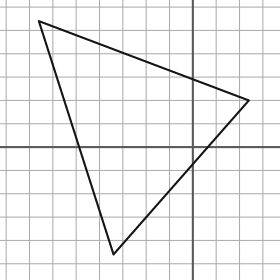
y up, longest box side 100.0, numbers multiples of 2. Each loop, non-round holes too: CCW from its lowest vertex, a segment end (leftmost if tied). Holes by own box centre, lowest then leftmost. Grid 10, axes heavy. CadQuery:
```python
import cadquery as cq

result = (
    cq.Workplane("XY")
    .moveTo(-34.0, -46.0)
    .lineTo(24.0, 20.0)
    .lineTo(-66.0, 54.0)
    .close()
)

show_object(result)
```